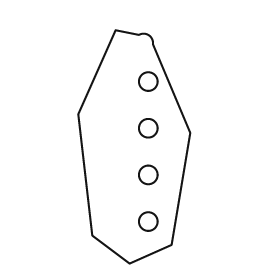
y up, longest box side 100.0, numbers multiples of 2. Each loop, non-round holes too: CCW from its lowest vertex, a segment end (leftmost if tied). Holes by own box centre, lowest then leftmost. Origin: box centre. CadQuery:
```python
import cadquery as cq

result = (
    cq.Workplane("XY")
    .moveTo(-2.0, -50.0)
    .lineTo(16.0, -42.0)
    .lineTo(24.0, 6.0)
    .lineTo(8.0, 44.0)
    .threePointArc((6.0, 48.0), (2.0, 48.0))
    .lineTo(-8.0, 50.0)
    .lineTo(-24.0, 14.0)
    .lineTo(-18.0, -38.0)
    .close()
    .moveTo(6.0, -32.0)
    .circle(4.0)
    .moveTo(6.0, -12.0)
    .circle(4.0)
    .moveTo(6.0, 8.0)
    .circle(4.0)
    .moveTo(6.0, 28.0)
    .circle(4.0)
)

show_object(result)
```